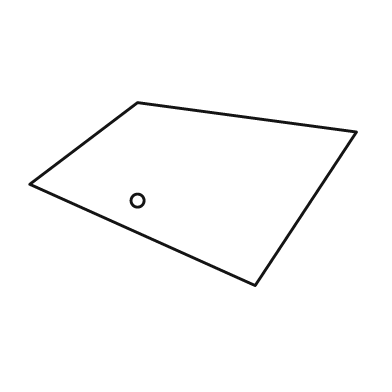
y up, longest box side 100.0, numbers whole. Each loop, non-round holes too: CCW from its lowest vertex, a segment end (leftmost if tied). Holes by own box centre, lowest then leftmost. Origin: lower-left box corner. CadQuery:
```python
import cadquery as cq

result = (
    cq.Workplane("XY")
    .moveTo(69.0, 0.0)
    .lineTo(100.0, 47.0)
    .lineTo(33.0, 56.0)
    .lineTo(0.0, 31.0)
    .close()
    .moveTo(33.0, 26.0)
    .circle(2.0)
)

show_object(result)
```